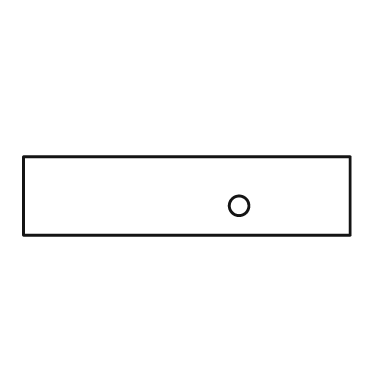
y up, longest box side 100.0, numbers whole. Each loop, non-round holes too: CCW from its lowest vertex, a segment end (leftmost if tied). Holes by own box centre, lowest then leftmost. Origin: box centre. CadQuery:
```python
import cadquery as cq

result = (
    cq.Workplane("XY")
    .moveTo(-50.0, -12.0)
    .lineTo(50.0, -12.0)
    .lineTo(50.0, 12.0)
    .lineTo(-50.0, 12.0)
    .close()
    .moveTo(16.0, -3.0)
    .circle(3.0)
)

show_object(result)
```